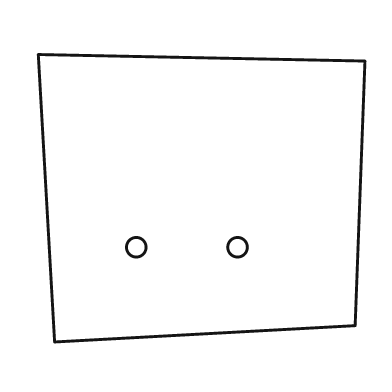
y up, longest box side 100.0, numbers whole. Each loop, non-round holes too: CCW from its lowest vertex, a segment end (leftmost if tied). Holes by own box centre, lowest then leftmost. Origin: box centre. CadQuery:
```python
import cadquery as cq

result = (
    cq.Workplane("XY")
    .moveTo(-45.0, -44.0)
    .lineTo(47.0, -39.0)
    .lineTo(50.0, 42.0)
    .lineTo(-50.0, 44.0)
    .close()
    .moveTo(-20.0, -15.0)
    .circle(3.0)
    .moveTo(11.0, -15.0)
    .circle(3.0)
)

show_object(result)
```